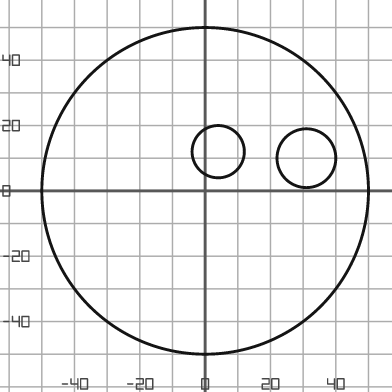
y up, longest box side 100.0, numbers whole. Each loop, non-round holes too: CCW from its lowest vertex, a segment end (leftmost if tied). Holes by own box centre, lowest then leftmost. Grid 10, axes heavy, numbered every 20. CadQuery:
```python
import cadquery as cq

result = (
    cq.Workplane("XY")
    .moveTo(0.0, 0.0)
    .circle(50.0)
    .moveTo(31.0, 10.0)
    .circle(9.0)
    .moveTo(4.0, 12.0)
    .circle(8.0)
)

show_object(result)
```